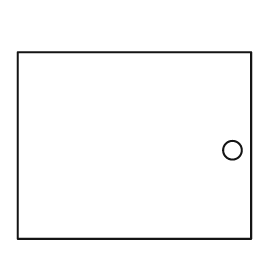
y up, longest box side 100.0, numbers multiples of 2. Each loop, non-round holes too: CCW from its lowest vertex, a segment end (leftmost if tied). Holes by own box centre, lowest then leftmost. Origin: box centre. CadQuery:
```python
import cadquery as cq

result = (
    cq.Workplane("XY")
    .moveTo(-50.0, -40.0)
    .lineTo(50.0, -40.0)
    .lineTo(50.0, 40.0)
    .lineTo(-50.0, 40.0)
    .close()
    .moveTo(42.0, -2.0)
    .circle(4.0)
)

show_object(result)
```